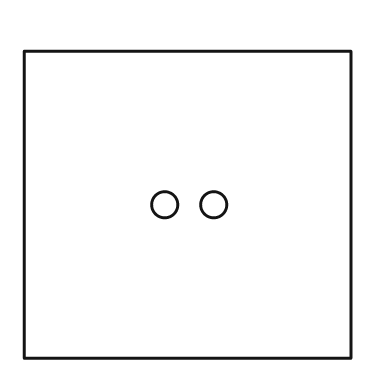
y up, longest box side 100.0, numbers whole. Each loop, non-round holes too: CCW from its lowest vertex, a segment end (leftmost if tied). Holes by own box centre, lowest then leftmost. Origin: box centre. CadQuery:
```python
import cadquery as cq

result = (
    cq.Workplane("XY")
    .moveTo(-50.0, -47.0)
    .lineTo(50.0, -47.0)
    .lineTo(50.0, 47.0)
    .lineTo(-50.0, 47.0)
    .close()
    .moveTo(-7.0, 0.0)
    .circle(4.0)
    .moveTo(8.0, 0.0)
    .circle(4.0)
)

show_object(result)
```